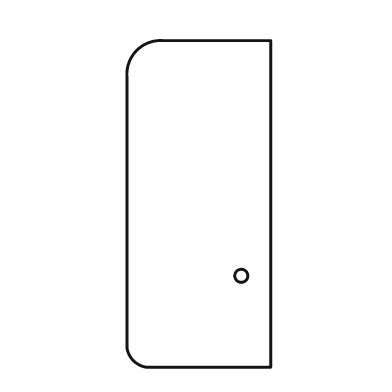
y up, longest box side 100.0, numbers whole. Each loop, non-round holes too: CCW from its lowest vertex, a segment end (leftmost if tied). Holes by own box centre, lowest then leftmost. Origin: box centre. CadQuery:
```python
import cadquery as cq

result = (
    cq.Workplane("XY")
    .moveTo(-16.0, -50.0)
    .lineTo(22.0, -50.0)
    .lineTo(22.0, 50.0)
    .lineTo(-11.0, 50.0)
    .threePointArc((-19.0, 47.0), (-22.0, 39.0))
    .lineTo(-22.0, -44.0)
    .threePointArc((-20.0, -48.0), (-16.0, -50.0))
    .close()
    .moveTo(13.0, -22.0)
    .circle(2.0)
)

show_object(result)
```